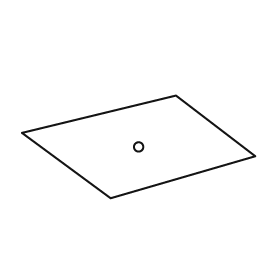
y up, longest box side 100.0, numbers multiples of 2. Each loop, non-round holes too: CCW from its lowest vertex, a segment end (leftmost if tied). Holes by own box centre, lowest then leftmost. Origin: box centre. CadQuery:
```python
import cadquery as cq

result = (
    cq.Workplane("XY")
    .moveTo(-12.0, -22.0)
    .lineTo(50.0, -4.0)
    .lineTo(16.0, 22.0)
    .lineTo(-50.0, 6.0)
    .close()
    .moveTo(0.0, 0.0)
    .circle(2.0)
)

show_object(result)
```